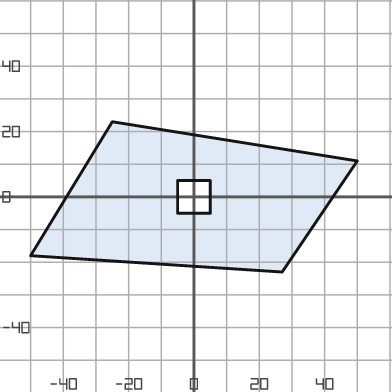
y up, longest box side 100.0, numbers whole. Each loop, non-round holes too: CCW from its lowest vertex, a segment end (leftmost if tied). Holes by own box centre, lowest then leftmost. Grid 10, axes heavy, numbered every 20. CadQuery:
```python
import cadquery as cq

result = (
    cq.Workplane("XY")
    .moveTo(27.0, -23.0)
    .lineTo(50.0, 11.0)
    .lineTo(-25.0, 23.0)
    .lineTo(-50.0, -18.0)
    .close()
    .moveTo(-5.0, -5.0)
    .lineTo(5.0, -5.0)
    .lineTo(5.0, 5.0)
    .lineTo(-5.0, 5.0)
    .close()
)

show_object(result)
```